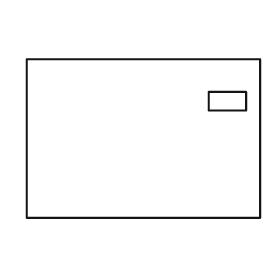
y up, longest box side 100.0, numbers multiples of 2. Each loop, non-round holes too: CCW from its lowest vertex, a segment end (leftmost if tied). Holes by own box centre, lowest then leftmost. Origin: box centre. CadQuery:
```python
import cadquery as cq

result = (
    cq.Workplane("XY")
    .moveTo(-50.0, -34.0)
    .lineTo(50.0, -34.0)
    .lineTo(50.0, 34.0)
    .lineTo(-50.0, 34.0)
    .close()
    .moveTo(28.0, 12.0)
    .lineTo(44.0, 12.0)
    .lineTo(44.0, 20.0)
    .lineTo(28.0, 20.0)
    .close()
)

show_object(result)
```